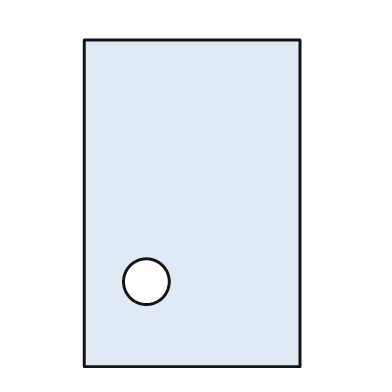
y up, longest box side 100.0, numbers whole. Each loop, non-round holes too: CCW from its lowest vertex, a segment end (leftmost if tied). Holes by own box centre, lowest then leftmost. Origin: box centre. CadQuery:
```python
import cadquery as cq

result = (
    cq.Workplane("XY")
    .moveTo(-33.0, -50.0)
    .lineTo(33.0, -50.0)
    .lineTo(33.0, 50.0)
    .lineTo(-33.0, 50.0)
    .close()
    .moveTo(-14.0, -24.0)
    .circle(7.0)
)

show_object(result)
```